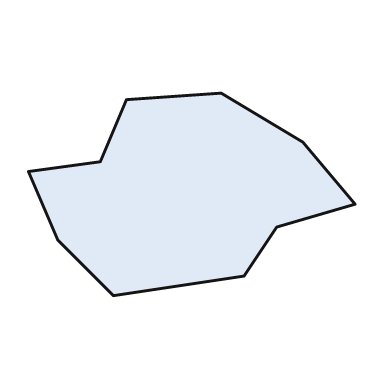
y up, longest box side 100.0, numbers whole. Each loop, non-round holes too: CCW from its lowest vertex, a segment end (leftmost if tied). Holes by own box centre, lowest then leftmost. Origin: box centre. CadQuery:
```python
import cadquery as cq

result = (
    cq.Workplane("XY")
    .moveTo(-24.0, -31.0)
    .lineTo(16.0, -25.0)
    .lineTo(26.0, -10.0)
    .lineTo(50.0, -3.0)
    .lineTo(34.0, 16.0)
    .lineTo(9.0, 31.0)
    .lineTo(-20.0, 29.0)
    .lineTo(-28.0, 10.0)
    .lineTo(-50.0, 7.0)
    .lineTo(-41.0, -14.0)
    .close()
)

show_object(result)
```